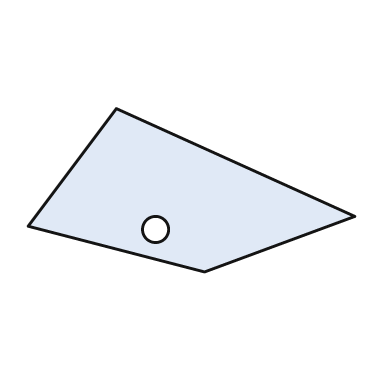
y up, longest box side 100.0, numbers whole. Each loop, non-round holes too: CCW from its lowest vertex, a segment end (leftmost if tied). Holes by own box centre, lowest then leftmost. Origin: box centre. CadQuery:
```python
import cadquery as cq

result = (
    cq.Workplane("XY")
    .moveTo(4.0, -25.0)
    .lineTo(50.0, -8.0)
    .lineTo(-23.0, 25.0)
    .lineTo(-50.0, -11.0)
    .close()
    .moveTo(-11.0, -12.0)
    .circle(4.0)
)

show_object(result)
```